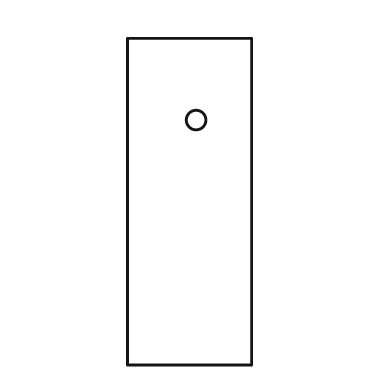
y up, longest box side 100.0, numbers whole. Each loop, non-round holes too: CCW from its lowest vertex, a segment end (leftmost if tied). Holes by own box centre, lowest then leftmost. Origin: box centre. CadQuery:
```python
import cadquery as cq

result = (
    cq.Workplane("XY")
    .moveTo(-19.0, -50.0)
    .lineTo(19.0, -50.0)
    .lineTo(19.0, 50.0)
    .lineTo(-19.0, 50.0)
    .close()
    .moveTo(2.0, 25.0)
    .circle(3.0)
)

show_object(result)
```